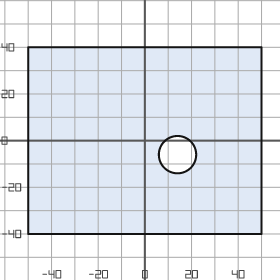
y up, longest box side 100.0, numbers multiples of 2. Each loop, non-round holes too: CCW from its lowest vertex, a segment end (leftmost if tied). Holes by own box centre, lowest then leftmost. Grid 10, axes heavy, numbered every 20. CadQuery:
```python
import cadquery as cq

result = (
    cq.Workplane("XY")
    .moveTo(-50.0, -40.0)
    .lineTo(50.0, -40.0)
    .lineTo(50.0, 40.0)
    .lineTo(-50.0, 40.0)
    .close()
    .moveTo(14.0, -6.0)
    .circle(8.0)
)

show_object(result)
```